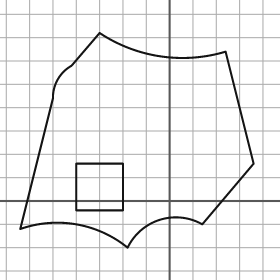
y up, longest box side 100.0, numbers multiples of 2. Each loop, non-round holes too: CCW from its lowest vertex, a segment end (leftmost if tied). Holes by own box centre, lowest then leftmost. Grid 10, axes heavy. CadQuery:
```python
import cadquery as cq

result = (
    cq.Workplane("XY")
    .moveTo(-18.0, -20.0)
    .threePointArc((-4.0, -8.0), (14.0, -10.0))
    .lineTo(36.0, 16.0)
    .lineTo(24.0, 64.0)
    .threePointArc((-4.0, 62.0), (-30.0, 72.0))
    .lineTo(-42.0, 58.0)
    .threePointArc((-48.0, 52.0), (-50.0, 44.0))
    .lineTo(-64.0, -12.0)
    .threePointArc((-40.0, -10.0), (-18.0, -20.0))
    .close()
    .moveTo(-40.0, -4.0)
    .lineTo(-20.0, -4.0)
    .lineTo(-20.0, 16.0)
    .lineTo(-40.0, 16.0)
    .close()
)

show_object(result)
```